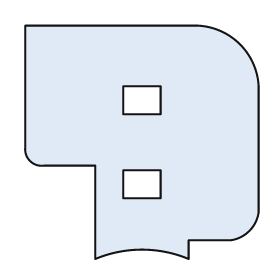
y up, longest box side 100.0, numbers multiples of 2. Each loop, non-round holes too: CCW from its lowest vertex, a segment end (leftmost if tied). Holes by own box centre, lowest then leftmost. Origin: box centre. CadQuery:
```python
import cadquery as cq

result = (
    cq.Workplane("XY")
    .moveTo(-20.0, -50.0)
    .threePointArc((0.0, -46.0), (20.0, -50.0))
    .lineTo(20.0, -42.0)
    .lineTo(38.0, -42.0)
    .threePointArc((46.0, -38.0), (50.0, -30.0))
    .lineTo(50.0, 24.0)
    .threePointArc((42.0, 42.0), (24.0, 50.0))
    .lineTo(-50.0, 50.0)
    .lineTo(-50.0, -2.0)
    .threePointArc((-48.0, -8.0), (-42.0, -10.0))
    .lineTo(-20.0, -10.0)
    .close()
    .moveTo(-8.0, -24.0)
    .lineTo(8.0, -24.0)
    .lineTo(8.0, -12.0)
    .lineTo(-8.0, -12.0)
    .close()
    .moveTo(-8.0, 12.0)
    .lineTo(8.0, 12.0)
    .lineTo(8.0, 24.0)
    .lineTo(-8.0, 24.0)
    .close()
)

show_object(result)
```